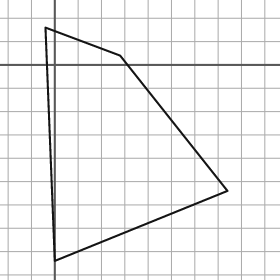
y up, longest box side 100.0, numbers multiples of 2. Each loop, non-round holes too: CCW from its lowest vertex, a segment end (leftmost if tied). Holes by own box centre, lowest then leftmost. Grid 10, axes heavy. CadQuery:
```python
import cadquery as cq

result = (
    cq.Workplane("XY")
    .moveTo(0.0, -84.0)
    .lineTo(74.0, -54.0)
    .lineTo(28.0, 4.0)
    .lineTo(-4.0, 16.0)
    .close()
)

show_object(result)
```